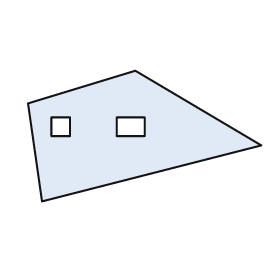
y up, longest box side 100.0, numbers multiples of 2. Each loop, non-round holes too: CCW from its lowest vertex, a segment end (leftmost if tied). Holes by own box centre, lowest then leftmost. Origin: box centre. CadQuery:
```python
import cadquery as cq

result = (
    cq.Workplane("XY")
    .moveTo(-44.0, -28.0)
    .lineTo(50.0, -4.0)
    .lineTo(-4.0, 28.0)
    .lineTo(-50.0, 14.0)
    .close()
    .moveTo(-40.0, 0.0)
    .lineTo(-32.0, 0.0)
    .lineTo(-32.0, 8.0)
    .lineTo(-40.0, 8.0)
    .close()
    .moveTo(-12.0, 0.0)
    .lineTo(0.0, 0.0)
    .lineTo(0.0, 8.0)
    .lineTo(-12.0, 8.0)
    .close()
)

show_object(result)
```